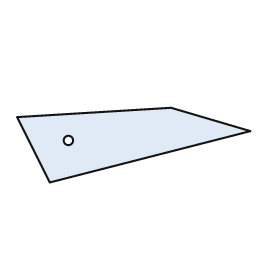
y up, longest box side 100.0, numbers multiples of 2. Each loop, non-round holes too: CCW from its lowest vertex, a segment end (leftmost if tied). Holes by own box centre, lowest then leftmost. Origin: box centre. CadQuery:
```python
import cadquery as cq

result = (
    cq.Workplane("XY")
    .moveTo(-36.0, -16.0)
    .lineTo(50.0, 6.0)
    .lineTo(16.0, 16.0)
    .lineTo(-50.0, 12.0)
    .close()
    .moveTo(-28.0, 2.0)
    .circle(2.0)
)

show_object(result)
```